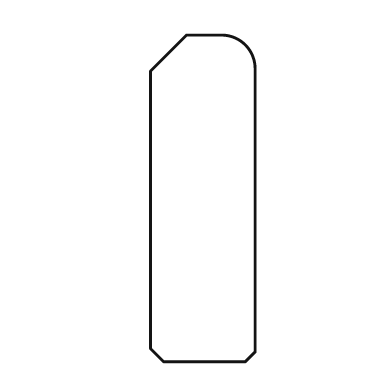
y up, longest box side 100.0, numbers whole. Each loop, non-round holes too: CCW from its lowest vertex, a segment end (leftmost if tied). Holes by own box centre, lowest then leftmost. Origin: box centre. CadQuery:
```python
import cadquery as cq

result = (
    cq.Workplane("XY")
    .moveTo(-12.0, -50.0)
    .lineTo(13.0, -50.0)
    .lineTo(16.0, -47.0)
    .lineTo(16.0, 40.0)
    .threePointArc((13.0, 47.0), (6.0, 50.0))
    .lineTo(-5.0, 50.0)
    .lineTo(-16.0, 39.0)
    .lineTo(-16.0, -46.0)
    .close()
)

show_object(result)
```